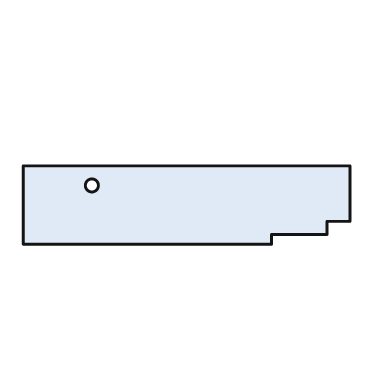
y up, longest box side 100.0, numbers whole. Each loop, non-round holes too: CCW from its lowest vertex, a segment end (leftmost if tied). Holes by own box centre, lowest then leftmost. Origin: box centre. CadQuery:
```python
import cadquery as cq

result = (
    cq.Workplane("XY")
    .moveTo(-50.0, -12.0)
    .lineTo(26.0, -12.0)
    .lineTo(26.0, -9.0)
    .lineTo(43.0, -9.0)
    .lineTo(43.0, -5.0)
    .lineTo(50.0, -5.0)
    .lineTo(50.0, 12.0)
    .lineTo(-50.0, 12.0)
    .close()
    .moveTo(-29.0, 6.0)
    .circle(2.0)
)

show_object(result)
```